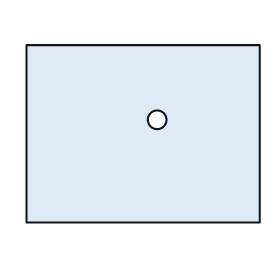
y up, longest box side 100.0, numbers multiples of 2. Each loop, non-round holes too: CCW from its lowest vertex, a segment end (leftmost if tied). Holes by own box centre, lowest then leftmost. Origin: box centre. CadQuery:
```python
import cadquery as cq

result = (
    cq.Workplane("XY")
    .moveTo(-50.0, -38.0)
    .lineTo(50.0, -38.0)
    .lineTo(50.0, 38.0)
    .lineTo(-50.0, 38.0)
    .close()
    .moveTo(6.0, 6.0)
    .circle(4.0)
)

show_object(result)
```